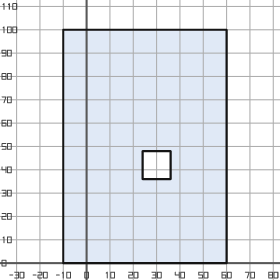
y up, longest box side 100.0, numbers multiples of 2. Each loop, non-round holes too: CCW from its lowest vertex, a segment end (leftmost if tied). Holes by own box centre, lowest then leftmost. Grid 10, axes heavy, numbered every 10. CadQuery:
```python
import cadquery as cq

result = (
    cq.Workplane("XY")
    .moveTo(-10.0, 0.0)
    .lineTo(60.0, 0.0)
    .lineTo(60.0, 100.0)
    .lineTo(-10.0, 100.0)
    .close()
    .moveTo(24.0, 36.0)
    .lineTo(36.0, 36.0)
    .lineTo(36.0, 48.0)
    .lineTo(24.0, 48.0)
    .close()
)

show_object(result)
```